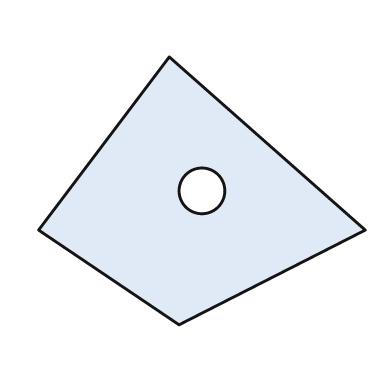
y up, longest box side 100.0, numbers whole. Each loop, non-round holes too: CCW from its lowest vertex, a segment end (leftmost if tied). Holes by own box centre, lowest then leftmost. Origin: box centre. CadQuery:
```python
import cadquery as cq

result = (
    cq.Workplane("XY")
    .moveTo(-7.0, -41.0)
    .lineTo(50.0, -12.0)
    .lineTo(-10.0, 41.0)
    .lineTo(-50.0, -12.0)
    .close()
    .moveTo(0.0, 0.0)
    .circle(7.0)
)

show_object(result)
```